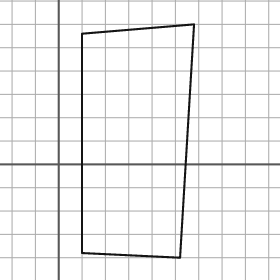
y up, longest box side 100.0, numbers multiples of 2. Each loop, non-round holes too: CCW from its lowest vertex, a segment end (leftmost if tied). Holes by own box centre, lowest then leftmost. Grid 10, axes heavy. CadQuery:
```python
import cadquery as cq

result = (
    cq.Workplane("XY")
    .moveTo(52.0, -40.0)
    .lineTo(58.0, 60.0)
    .lineTo(10.0, 56.0)
    .lineTo(10.0, -38.0)
    .close()
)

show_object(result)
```